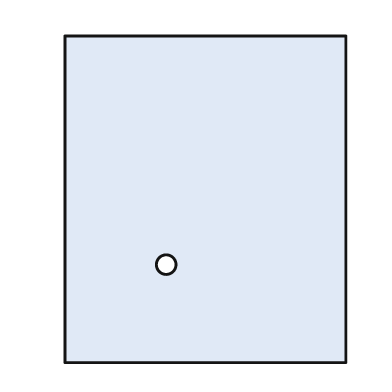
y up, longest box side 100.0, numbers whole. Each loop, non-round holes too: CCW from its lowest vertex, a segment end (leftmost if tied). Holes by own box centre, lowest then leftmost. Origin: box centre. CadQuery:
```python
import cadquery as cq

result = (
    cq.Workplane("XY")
    .moveTo(-43.0, -50.0)
    .lineTo(43.0, -50.0)
    .lineTo(43.0, 50.0)
    .lineTo(-43.0, 50.0)
    .close()
    .moveTo(-12.0, -20.0)
    .circle(3.0)
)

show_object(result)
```